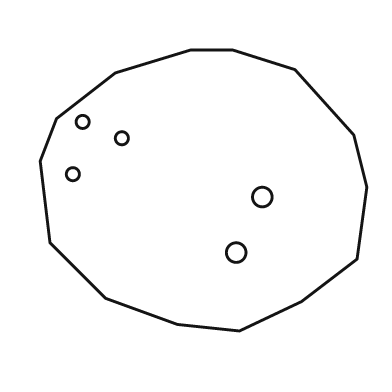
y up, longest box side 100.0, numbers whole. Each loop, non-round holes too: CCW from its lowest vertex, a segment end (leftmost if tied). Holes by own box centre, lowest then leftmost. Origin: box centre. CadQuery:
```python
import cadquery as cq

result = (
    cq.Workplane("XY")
    .moveTo(11.0, -43.0)
    .lineTo(30.0, -34.0)
    .lineTo(47.0, -21.0)
    .lineTo(50.0, 1.0)
    .lineTo(46.0, 17.0)
    .lineTo(28.0, 37.0)
    .lineTo(9.0, 43.0)
    .lineTo(-4.0, 43.0)
    .lineTo(-27.0, 36.0)
    .lineTo(-45.0, 22.0)
    .lineTo(-50.0, 9.0)
    .lineTo(-47.0, -16.0)
    .lineTo(-30.0, -33.0)
    .lineTo(-8.0, -41.0)
    .close()
    .moveTo(10.0, -19.0)
    .circle(3.0)
    .moveTo(18.0, -2.0)
    .circle(3.0)
    .moveTo(-40.0, 5.0)
    .circle(2.0)
    .moveTo(-25.0, 16.0)
    .circle(2.0)
    .moveTo(-37.0, 21.0)
    .circle(2.0)
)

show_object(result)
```